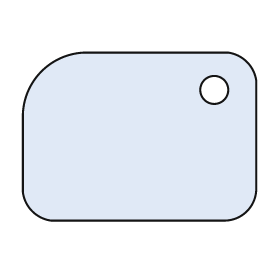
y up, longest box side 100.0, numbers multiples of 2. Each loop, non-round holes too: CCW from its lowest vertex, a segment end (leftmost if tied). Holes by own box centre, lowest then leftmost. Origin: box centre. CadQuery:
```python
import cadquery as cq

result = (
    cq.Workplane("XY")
    .moveTo(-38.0, -36.0)
    .lineTo(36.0, -36.0)
    .threePointArc((46.0, -32.0), (50.0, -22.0))
    .lineTo(50.0, 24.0)
    .threePointArc((46.0, 32.0), (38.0, 36.0))
    .lineTo(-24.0, 36.0)
    .threePointArc((-42.0, 28.0), (-50.0, 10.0))
    .lineTo(-50.0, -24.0)
    .threePointArc((-46.0, -32.0), (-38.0, -36.0))
    .close()
    .moveTo(32.0, 20.0)
    .circle(6.0)
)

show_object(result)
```